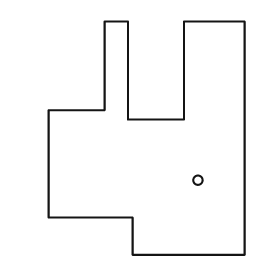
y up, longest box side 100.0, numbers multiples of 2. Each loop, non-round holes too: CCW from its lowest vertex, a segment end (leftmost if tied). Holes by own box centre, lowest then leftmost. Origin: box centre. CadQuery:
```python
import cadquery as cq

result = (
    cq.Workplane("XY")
    .moveTo(-6.0, -50.0)
    .lineTo(42.0, -50.0)
    .lineTo(42.0, 50.0)
    .lineTo(16.0, 50.0)
    .lineTo(16.0, 8.0)
    .lineTo(-8.0, 8.0)
    .lineTo(-8.0, 50.0)
    .lineTo(-18.0, 50.0)
    .lineTo(-18.0, 12.0)
    .lineTo(-42.0, 12.0)
    .lineTo(-42.0, -34.0)
    .lineTo(-6.0, -34.0)
    .close()
    .moveTo(22.0, -18.0)
    .circle(2.0)
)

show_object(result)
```